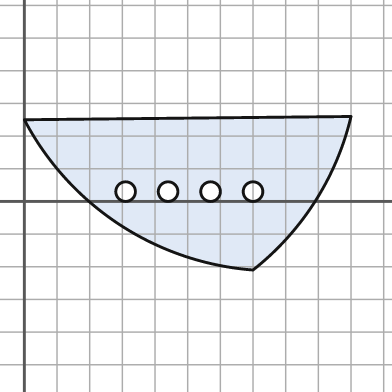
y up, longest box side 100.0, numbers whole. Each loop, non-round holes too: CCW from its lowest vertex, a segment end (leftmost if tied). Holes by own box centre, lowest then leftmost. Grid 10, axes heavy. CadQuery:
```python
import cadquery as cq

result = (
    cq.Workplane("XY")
    .moveTo(70.0, -21.0)
    .threePointArc((89.0, 0.0), (100.0, 26.0))
    .lineTo(0.0, 25.0)
    .threePointArc((29.0, -7.0), (70.0, -21.0))
    .close()
    .moveTo(31.0, 3.0)
    .circle(3.0)
    .moveTo(44.0, 3.0)
    .circle(3.0)
    .moveTo(57.0, 3.0)
    .circle(3.0)
    .moveTo(70.0, 3.0)
    .circle(3.0)
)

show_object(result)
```